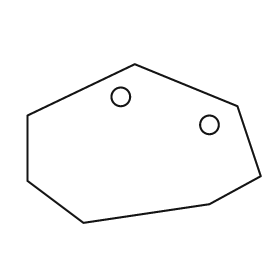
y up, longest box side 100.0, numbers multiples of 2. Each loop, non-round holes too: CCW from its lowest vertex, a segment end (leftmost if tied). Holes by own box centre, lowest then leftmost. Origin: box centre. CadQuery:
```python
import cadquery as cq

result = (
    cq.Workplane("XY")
    .moveTo(-26.0, -34.0)
    .lineTo(28.0, -26.0)
    .lineTo(50.0, -14.0)
    .lineTo(40.0, 16.0)
    .lineTo(-4.0, 34.0)
    .lineTo(-50.0, 12.0)
    .lineTo(-50.0, -16.0)
    .close()
    .moveTo(28.0, 8.0)
    .circle(4.0)
    .moveTo(-10.0, 20.0)
    .circle(4.0)
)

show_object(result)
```